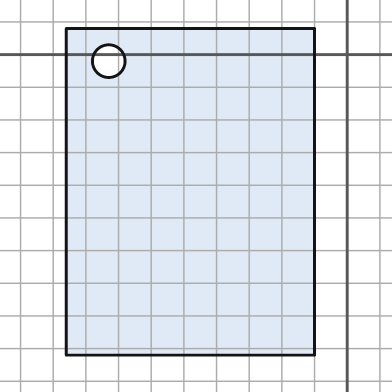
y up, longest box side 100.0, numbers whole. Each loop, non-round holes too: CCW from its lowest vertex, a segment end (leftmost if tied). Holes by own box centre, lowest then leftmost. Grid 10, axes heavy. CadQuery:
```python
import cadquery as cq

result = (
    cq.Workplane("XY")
    .moveTo(-86.0, -92.0)
    .lineTo(-10.0, -92.0)
    .lineTo(-10.0, 8.0)
    .lineTo(-86.0, 8.0)
    .close()
    .moveTo(-73.0, -2.0)
    .circle(5.0)
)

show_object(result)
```